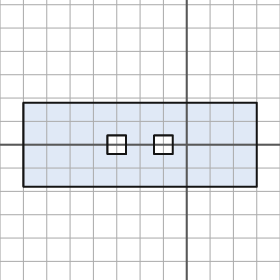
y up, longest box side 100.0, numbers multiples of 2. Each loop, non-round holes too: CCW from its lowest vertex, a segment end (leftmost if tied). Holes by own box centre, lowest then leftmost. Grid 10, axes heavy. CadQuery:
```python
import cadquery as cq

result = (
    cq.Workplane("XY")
    .moveTo(-70.0, -18.0)
    .lineTo(30.0, -18.0)
    .lineTo(30.0, 18.0)
    .lineTo(-70.0, 18.0)
    .close()
    .moveTo(-34.0, -4.0)
    .lineTo(-26.0, -4.0)
    .lineTo(-26.0, 4.0)
    .lineTo(-34.0, 4.0)
    .close()
    .moveTo(-14.0, -4.0)
    .lineTo(-6.0, -4.0)
    .lineTo(-6.0, 4.0)
    .lineTo(-14.0, 4.0)
    .close()
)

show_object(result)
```